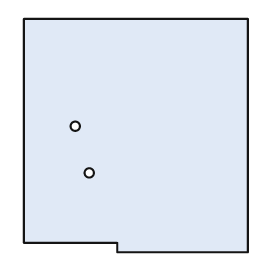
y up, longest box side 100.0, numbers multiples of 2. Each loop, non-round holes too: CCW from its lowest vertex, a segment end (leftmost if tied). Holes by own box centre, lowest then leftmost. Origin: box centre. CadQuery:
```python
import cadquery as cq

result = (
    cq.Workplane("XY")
    .moveTo(-8.0, -50.0)
    .lineTo(48.0, -50.0)
    .lineTo(48.0, 50.0)
    .lineTo(-48.0, 50.0)
    .lineTo(-48.0, -46.0)
    .lineTo(-8.0, -46.0)
    .close()
    .moveTo(-20.0, -16.0)
    .circle(2.0)
    .moveTo(-26.0, 4.0)
    .circle(2.0)
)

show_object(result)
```